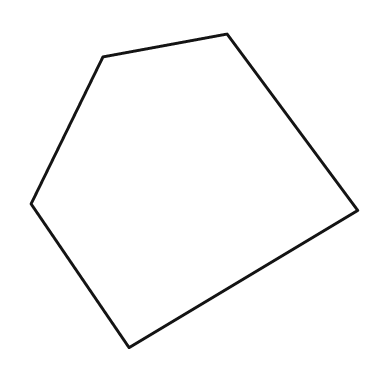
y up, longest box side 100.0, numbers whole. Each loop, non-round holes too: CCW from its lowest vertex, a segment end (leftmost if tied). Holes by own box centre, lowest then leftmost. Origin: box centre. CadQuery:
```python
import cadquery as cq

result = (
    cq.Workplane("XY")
    .moveTo(-20.0, -48.0)
    .lineTo(50.0, -6.0)
    .lineTo(10.0, 48.0)
    .lineTo(-28.0, 41.0)
    .lineTo(-50.0, -4.0)
    .close()
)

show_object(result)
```